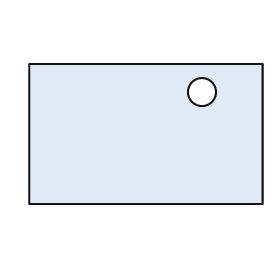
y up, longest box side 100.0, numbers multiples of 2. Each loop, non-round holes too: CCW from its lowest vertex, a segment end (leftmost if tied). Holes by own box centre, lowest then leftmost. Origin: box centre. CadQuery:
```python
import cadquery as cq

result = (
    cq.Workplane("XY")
    .moveTo(-50.0, -30.0)
    .lineTo(50.0, -30.0)
    .lineTo(50.0, 30.0)
    .lineTo(-50.0, 30.0)
    .close()
    .moveTo(24.0, 18.0)
    .circle(6.0)
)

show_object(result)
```